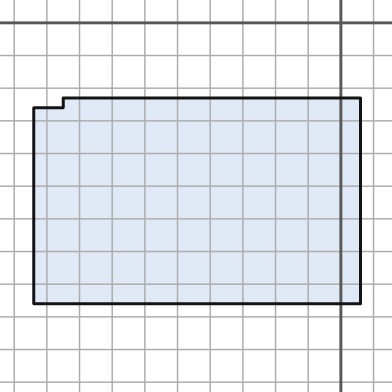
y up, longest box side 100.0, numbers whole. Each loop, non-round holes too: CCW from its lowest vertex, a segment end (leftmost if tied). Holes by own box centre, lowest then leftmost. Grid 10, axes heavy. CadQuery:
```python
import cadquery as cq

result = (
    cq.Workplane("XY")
    .moveTo(-94.0, -86.0)
    .lineTo(6.0, -86.0)
    .lineTo(6.0, -23.0)
    .lineTo(-85.0, -23.0)
    .lineTo(-85.0, -26.0)
    .lineTo(-94.0, -26.0)
    .close()
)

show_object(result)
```